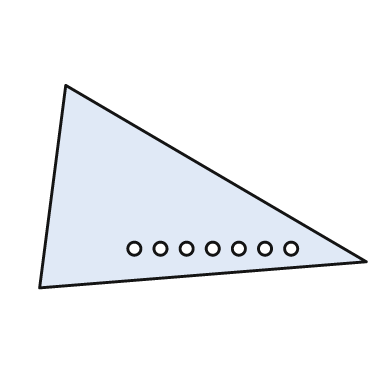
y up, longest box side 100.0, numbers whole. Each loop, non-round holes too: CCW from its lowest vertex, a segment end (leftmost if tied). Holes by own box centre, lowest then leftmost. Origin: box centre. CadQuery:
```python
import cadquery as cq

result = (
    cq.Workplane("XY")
    .moveTo(-50.0, -31.0)
    .lineTo(50.0, -23.0)
    .lineTo(-42.0, 31.0)
    .close()
    .moveTo(-21.0, -19.0)
    .circle(2.0)
    .moveTo(-13.0, -19.0)
    .circle(2.0)
    .moveTo(-5.0, -19.0)
    .circle(2.0)
    .moveTo(3.0, -19.0)
    .circle(2.0)
    .moveTo(11.0, -19.0)
    .circle(2.0)
    .moveTo(19.0, -19.0)
    .circle(2.0)
    .moveTo(27.0, -19.0)
    .circle(2.0)
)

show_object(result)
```